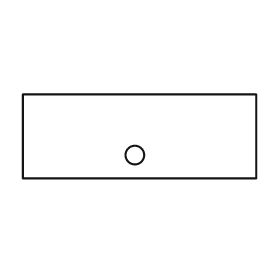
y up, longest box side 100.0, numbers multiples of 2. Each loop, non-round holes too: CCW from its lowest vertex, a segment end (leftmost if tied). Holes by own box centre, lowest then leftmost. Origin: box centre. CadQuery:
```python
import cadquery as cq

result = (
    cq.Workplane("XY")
    .moveTo(-50.0, -18.0)
    .lineTo(50.0, -18.0)
    .lineTo(50.0, 18.0)
    .lineTo(-50.0, 18.0)
    .close()
    .moveTo(-2.0, -8.0)
    .circle(4.0)
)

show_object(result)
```